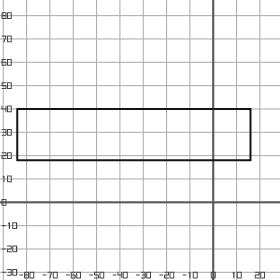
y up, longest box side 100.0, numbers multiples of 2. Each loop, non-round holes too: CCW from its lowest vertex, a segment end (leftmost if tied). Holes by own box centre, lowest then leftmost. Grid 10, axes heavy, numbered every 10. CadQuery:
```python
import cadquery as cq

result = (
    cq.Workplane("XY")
    .moveTo(-84.0, 18.0)
    .lineTo(16.0, 18.0)
    .lineTo(16.0, 40.0)
    .lineTo(-84.0, 40.0)
    .close()
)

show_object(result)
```